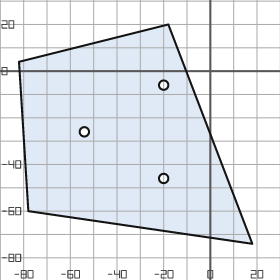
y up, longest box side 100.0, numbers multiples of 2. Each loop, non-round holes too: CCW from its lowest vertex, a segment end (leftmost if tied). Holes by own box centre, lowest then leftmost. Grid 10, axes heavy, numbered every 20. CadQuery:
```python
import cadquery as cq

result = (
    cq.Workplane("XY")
    .moveTo(18.0, -74.0)
    .lineTo(-18.0, 20.0)
    .lineTo(-82.0, 4.0)
    .lineTo(-78.0, -60.0)
    .close()
    .moveTo(-20.0, -46.0)
    .circle(2.0)
    .moveTo(-54.0, -26.0)
    .circle(2.0)
    .moveTo(-20.0, -6.0)
    .circle(2.0)
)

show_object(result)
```